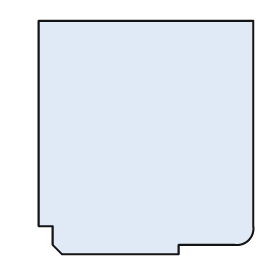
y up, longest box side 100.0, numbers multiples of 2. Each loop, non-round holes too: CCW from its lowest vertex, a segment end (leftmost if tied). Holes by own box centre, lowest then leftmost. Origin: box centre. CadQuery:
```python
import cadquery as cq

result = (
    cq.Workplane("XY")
    .moveTo(-36.0, -50.0)
    .lineTo(14.0, -50.0)
    .lineTo(14.0, -46.0)
    .lineTo(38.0, -46.0)
    .threePointArc((44.0, -44.0), (46.0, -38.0))
    .lineTo(46.0, 50.0)
    .lineTo(-46.0, 50.0)
    .lineTo(-46.0, -38.0)
    .lineTo(-40.0, -38.0)
    .lineTo(-40.0, -46.0)
    .close()
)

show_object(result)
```